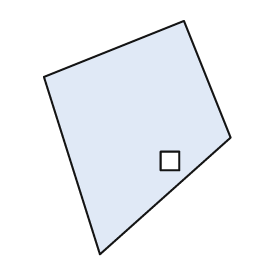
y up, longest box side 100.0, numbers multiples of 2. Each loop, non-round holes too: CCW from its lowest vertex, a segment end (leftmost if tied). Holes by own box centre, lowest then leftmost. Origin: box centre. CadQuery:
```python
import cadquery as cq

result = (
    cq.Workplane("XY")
    .moveTo(-16.0, -50.0)
    .lineTo(40.0, 0.0)
    .lineTo(20.0, 50.0)
    .lineTo(-40.0, 26.0)
    .close()
    .moveTo(10.0, -14.0)
    .lineTo(18.0, -14.0)
    .lineTo(18.0, -6.0)
    .lineTo(10.0, -6.0)
    .close()
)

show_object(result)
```